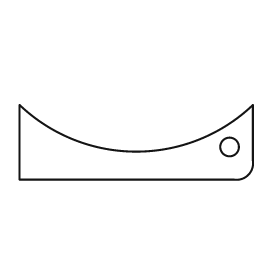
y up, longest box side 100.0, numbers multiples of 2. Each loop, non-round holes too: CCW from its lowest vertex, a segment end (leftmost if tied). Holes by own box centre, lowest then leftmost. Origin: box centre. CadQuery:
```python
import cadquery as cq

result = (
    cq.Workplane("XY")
    .moveTo(-50.0, -16.0)
    .lineTo(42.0, -16.0)
    .threePointArc((48.0, -14.0), (50.0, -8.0))
    .lineTo(50.0, 16.0)
    .threePointArc((0.0, -4.0), (-50.0, 16.0))
    .close()
    .moveTo(40.0, -2.0)
    .circle(4.0)
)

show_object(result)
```